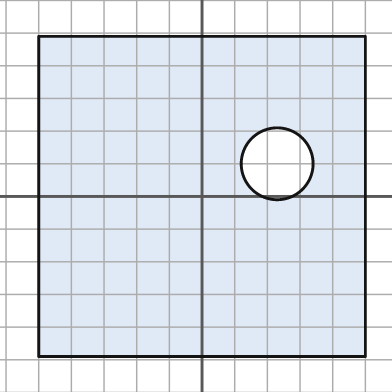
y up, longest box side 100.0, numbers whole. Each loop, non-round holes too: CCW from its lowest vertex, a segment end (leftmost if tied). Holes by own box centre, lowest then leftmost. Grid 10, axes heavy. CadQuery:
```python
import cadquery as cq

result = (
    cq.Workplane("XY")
    .moveTo(-50.0, -49.0)
    .lineTo(50.0, -49.0)
    .lineTo(50.0, 49.0)
    .lineTo(-50.0, 49.0)
    .close()
    .moveTo(23.0, 10.0)
    .circle(11.0)
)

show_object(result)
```